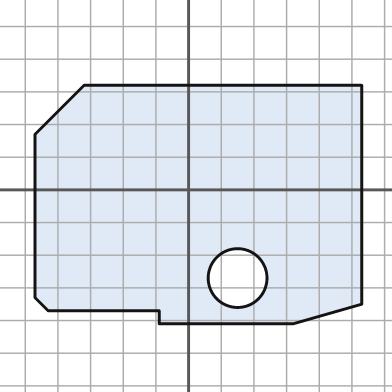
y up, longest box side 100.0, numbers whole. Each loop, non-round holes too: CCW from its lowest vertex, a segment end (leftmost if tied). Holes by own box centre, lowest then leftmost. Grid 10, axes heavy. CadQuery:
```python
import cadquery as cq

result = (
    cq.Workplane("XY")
    .moveTo(-9.0, -41.0)
    .lineTo(32.0, -41.0)
    .lineTo(53.0, -35.0)
    .lineTo(53.0, 32.0)
    .lineTo(-32.0, 32.0)
    .lineTo(-47.0, 17.0)
    .lineTo(-47.0, -33.0)
    .lineTo(-43.0, -37.0)
    .lineTo(-9.0, -37.0)
    .close()
    .moveTo(15.0, -27.0)
    .circle(9.0)
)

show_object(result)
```